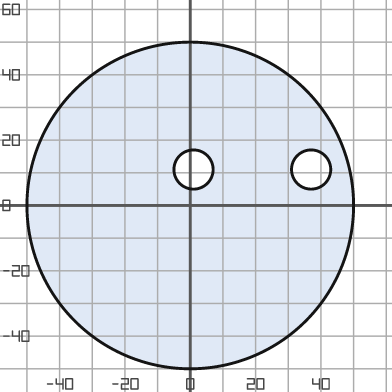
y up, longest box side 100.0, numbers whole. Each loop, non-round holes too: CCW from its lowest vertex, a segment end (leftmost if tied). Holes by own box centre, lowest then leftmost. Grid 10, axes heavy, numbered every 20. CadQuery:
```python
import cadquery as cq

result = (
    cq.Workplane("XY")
    .moveTo(0.0, 0.0)
    .circle(50.0)
    .moveTo(1.0, 11.0)
    .circle(6.0)
    .moveTo(37.0, 11.0)
    .circle(6.0)
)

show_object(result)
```